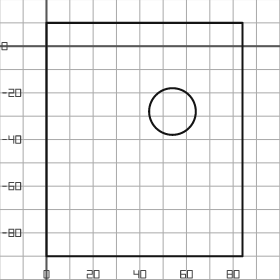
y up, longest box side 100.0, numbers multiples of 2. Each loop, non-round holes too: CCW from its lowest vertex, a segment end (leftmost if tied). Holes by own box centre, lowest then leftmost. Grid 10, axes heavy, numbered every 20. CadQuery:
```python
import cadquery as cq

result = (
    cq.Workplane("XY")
    .moveTo(0.0, -90.0)
    .lineTo(84.0, -90.0)
    .lineTo(84.0, 10.0)
    .lineTo(0.0, 10.0)
    .close()
    .moveTo(54.0, -28.0)
    .circle(10.0)
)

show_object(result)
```